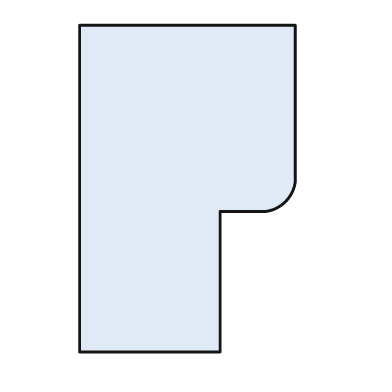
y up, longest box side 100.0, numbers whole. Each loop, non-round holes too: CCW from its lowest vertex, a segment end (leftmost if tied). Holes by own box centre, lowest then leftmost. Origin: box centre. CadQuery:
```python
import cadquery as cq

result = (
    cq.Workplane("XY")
    .moveTo(-33.0, -50.0)
    .lineTo(10.0, -50.0)
    .lineTo(10.0, -7.0)
    .lineTo(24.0, -7.0)
    .threePointArc((30.0, -4.0), (33.0, 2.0))
    .lineTo(33.0, 50.0)
    .lineTo(-33.0, 50.0)
    .close()
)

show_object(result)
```